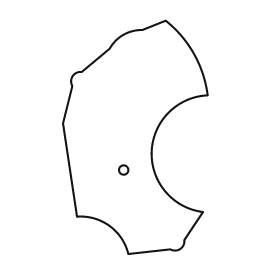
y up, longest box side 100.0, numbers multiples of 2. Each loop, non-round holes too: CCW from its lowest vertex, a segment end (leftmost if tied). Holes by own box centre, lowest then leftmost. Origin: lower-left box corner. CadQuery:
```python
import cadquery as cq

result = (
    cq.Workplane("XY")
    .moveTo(28.0, 0.0)
    .lineTo(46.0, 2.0)
    .threePointArc((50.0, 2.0), (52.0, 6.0))
    .lineTo(60.0, 18.0)
    .threePointArc((38.0, 44.0), (62.0, 68.0))
    .threePointArc((56.0, 86.0), (44.0, 100.0))
    .lineTo(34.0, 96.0)
    .threePointArc((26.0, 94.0), (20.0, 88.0))
    .lineTo(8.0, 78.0)
    .threePointArc((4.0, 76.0), (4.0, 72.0))
    .lineTo(0.0, 56.0)
    .lineTo(6.0, 16.0)
    .threePointArc((20.0, 12.0), (28.0, 0.0))
    .close()
    .moveTo(26.0, 36.0)
    .circle(2.0)
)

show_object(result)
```